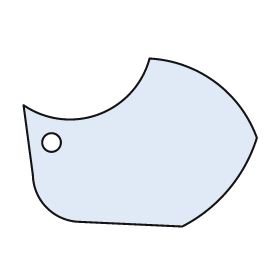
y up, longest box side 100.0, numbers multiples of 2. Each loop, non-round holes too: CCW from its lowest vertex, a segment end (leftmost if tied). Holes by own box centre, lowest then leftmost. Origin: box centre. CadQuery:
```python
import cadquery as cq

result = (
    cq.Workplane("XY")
    .moveTo(18.0, -36.0)
    .threePointArc((38.0, -20.0), (50.0, 2.0))
    .threePointArc((32.0, 26.0), (4.0, 36.0))
    .threePointArc((-18.0, 12.0), (-50.0, 16.0))
    .lineTo(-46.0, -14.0)
    .threePointArc((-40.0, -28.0), (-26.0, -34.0))
    .close()
    .moveTo(-38.0, 0.0)
    .circle(4.0)
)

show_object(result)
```